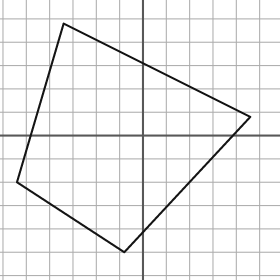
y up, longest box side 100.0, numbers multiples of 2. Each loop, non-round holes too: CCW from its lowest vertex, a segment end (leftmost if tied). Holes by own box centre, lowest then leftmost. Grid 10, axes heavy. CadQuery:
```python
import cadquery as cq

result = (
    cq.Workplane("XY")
    .moveTo(-8.0, -50.0)
    .lineTo(46.0, 8.0)
    .lineTo(-34.0, 48.0)
    .lineTo(-54.0, -20.0)
    .close()
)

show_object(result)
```